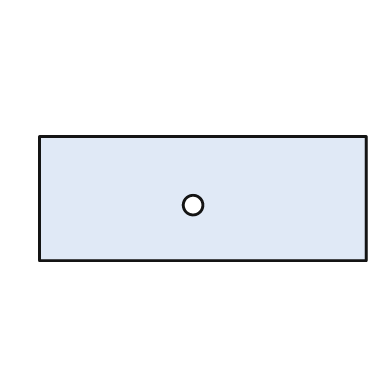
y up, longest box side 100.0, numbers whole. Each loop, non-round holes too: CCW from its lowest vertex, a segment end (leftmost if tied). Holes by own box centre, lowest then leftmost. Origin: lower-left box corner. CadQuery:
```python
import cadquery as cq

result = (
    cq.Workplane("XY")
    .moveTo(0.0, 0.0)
    .lineTo(100.0, 0.0)
    .lineTo(100.0, 38.0)
    .lineTo(0.0, 38.0)
    .close()
    .moveTo(47.0, 17.0)
    .circle(3.0)
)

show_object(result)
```